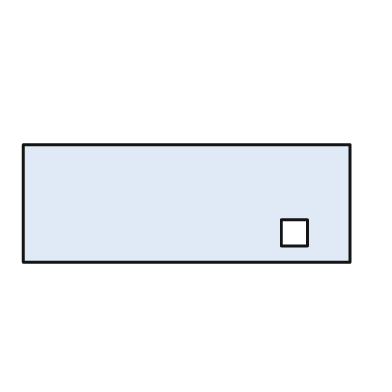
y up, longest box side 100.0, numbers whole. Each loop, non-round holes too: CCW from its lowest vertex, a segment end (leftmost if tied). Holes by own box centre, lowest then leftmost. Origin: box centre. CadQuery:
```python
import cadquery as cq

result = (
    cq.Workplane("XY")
    .moveTo(-50.0, -18.0)
    .lineTo(50.0, -18.0)
    .lineTo(50.0, 18.0)
    .lineTo(-50.0, 18.0)
    .close()
    .moveTo(29.0, -13.0)
    .lineTo(37.0, -13.0)
    .lineTo(37.0, -5.0)
    .lineTo(29.0, -5.0)
    .close()
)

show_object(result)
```